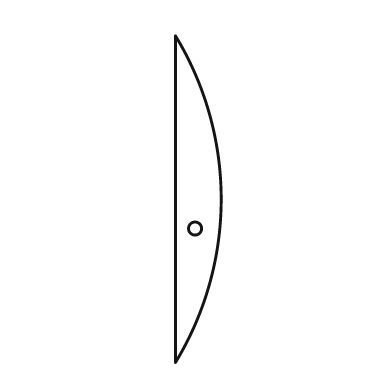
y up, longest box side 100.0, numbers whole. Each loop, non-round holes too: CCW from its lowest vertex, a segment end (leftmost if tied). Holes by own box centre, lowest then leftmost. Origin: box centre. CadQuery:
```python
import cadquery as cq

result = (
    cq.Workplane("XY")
    .moveTo(-7.0, -50.0)
    .threePointArc((7.0, 0.0), (-7.0, 50.0))
    .close()
    .moveTo(-1.0, -9.0)
    .circle(2.0)
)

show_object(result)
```